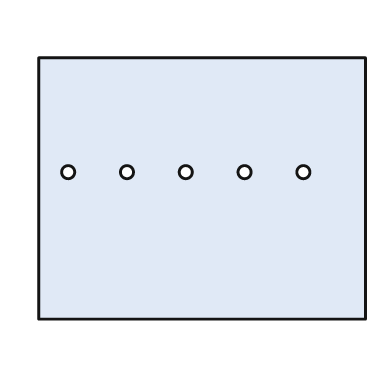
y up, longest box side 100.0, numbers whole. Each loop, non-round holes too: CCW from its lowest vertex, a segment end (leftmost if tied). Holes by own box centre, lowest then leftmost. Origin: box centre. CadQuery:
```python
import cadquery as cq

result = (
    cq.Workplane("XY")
    .moveTo(-50.0, -40.0)
    .lineTo(50.0, -40.0)
    .lineTo(50.0, 40.0)
    .lineTo(-50.0, 40.0)
    .close()
    .moveTo(-41.0, 5.0)
    .circle(2.0)
    .moveTo(-23.0, 5.0)
    .circle(2.0)
    .moveTo(-5.0, 5.0)
    .circle(2.0)
    .moveTo(13.0, 5.0)
    .circle(2.0)
    .moveTo(31.0, 5.0)
    .circle(2.0)
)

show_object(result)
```